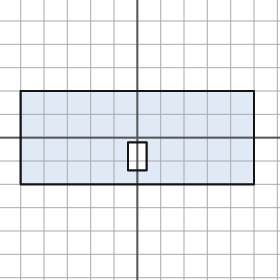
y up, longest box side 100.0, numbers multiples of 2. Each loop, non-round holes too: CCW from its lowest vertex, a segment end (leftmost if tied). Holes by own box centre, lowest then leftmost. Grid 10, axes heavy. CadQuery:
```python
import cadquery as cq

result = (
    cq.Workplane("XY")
    .moveTo(-50.0, -20.0)
    .lineTo(50.0, -20.0)
    .lineTo(50.0, 20.0)
    .lineTo(-50.0, 20.0)
    .close()
    .moveTo(-4.0, -14.0)
    .lineTo(4.0, -14.0)
    .lineTo(4.0, -2.0)
    .lineTo(-4.0, -2.0)
    .close()
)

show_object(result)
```